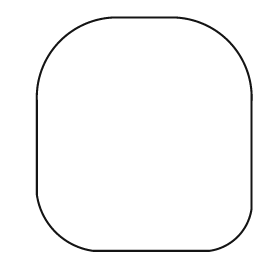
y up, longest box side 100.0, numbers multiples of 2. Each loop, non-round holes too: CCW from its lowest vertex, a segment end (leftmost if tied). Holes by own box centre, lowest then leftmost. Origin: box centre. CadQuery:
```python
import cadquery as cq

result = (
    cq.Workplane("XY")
    .moveTo(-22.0, -50.0)
    .lineTo(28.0, -50.0)
    .threePointArc((40.0, -44.0), (46.0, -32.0))
    .lineTo(46.0, 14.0)
    .threePointArc((36.0, 40.0), (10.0, 50.0))
    .lineTo(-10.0, 50.0)
    .threePointArc((-36.0, 40.0), (-46.0, 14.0))
    .lineTo(-46.0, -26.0)
    .threePointArc((-38.0, -42.0), (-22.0, -50.0))
    .close()
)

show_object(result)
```